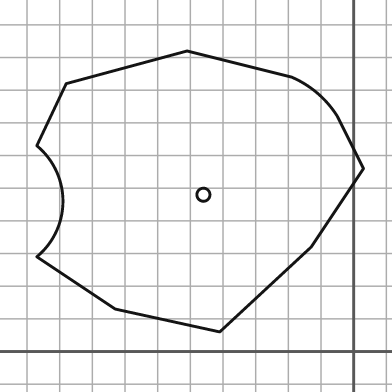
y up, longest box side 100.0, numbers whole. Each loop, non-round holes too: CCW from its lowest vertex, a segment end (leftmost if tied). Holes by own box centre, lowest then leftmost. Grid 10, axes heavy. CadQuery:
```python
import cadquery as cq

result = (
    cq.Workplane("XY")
    .moveTo(-41.0, 6.0)
    .lineTo(-13.0, 32.0)
    .lineTo(3.0, 56.0)
    .lineTo(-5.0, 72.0)
    .threePointArc((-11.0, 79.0), (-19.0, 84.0))
    .lineTo(-51.0, 92.0)
    .lineTo(-88.0, 82.0)
    .lineTo(-97.0, 63.0)
    .threePointArc((-89.0, 46.0), (-97.0, 29.0))
    .lineTo(-73.0, 13.0)
    .close()
    .moveTo(-46.0, 48.0)
    .circle(2.0)
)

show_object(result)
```